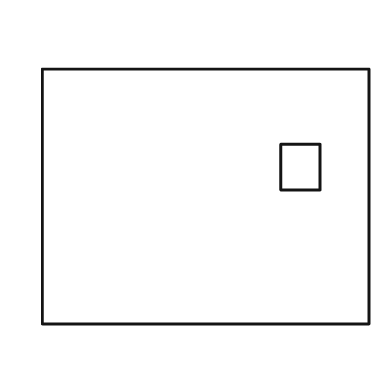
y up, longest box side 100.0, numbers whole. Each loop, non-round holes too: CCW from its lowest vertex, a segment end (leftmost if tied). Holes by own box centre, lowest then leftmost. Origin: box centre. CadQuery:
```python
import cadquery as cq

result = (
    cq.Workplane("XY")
    .moveTo(-50.0, -39.0)
    .lineTo(50.0, -39.0)
    .lineTo(50.0, 39.0)
    .lineTo(-50.0, 39.0)
    .close()
    .moveTo(23.0, 2.0)
    .lineTo(35.0, 2.0)
    .lineTo(35.0, 16.0)
    .lineTo(23.0, 16.0)
    .close()
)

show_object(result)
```